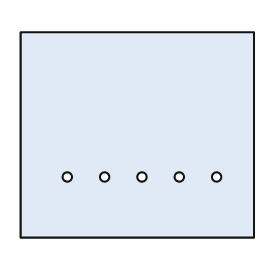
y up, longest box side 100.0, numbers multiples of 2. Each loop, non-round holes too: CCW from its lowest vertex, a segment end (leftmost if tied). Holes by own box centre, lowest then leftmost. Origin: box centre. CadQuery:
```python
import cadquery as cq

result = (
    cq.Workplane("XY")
    .moveTo(-50.0, -44.0)
    .lineTo(50.0, -44.0)
    .lineTo(50.0, 44.0)
    .lineTo(-50.0, 44.0)
    .close()
    .moveTo(-30.0, -18.0)
    .circle(2.0)
    .moveTo(-14.0, -18.0)
    .circle(2.0)
    .moveTo(2.0, -18.0)
    .circle(2.0)
    .moveTo(18.0, -18.0)
    .circle(2.0)
    .moveTo(34.0, -18.0)
    .circle(2.0)
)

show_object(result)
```